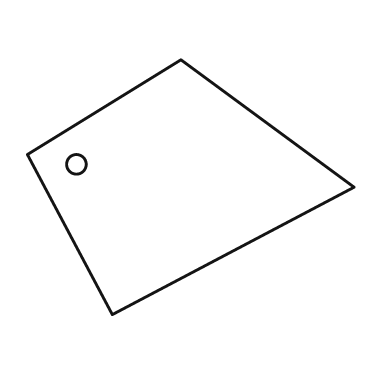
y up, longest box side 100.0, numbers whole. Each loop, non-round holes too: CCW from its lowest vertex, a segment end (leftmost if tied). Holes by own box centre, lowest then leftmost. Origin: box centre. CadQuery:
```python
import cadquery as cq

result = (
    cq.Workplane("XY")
    .moveTo(-24.0, -39.0)
    .lineTo(50.0, 0.0)
    .lineTo(-3.0, 39.0)
    .lineTo(-50.0, 10.0)
    .close()
    .moveTo(-35.0, 7.0)
    .circle(3.0)
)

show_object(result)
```